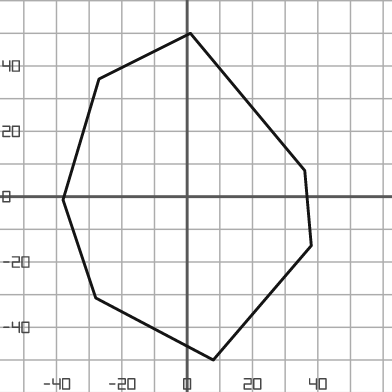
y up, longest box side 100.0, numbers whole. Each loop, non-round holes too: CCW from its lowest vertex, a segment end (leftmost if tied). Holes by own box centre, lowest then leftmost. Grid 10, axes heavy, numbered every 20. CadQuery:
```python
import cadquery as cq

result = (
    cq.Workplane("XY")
    .moveTo(8.0, -50.0)
    .lineTo(38.0, -15.0)
    .lineTo(36.0, 8.0)
    .lineTo(1.0, 50.0)
    .lineTo(-27.0, 36.0)
    .lineTo(-38.0, -1.0)
    .lineTo(-28.0, -31.0)
    .close()
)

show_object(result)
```